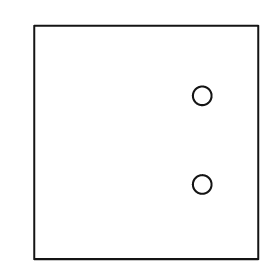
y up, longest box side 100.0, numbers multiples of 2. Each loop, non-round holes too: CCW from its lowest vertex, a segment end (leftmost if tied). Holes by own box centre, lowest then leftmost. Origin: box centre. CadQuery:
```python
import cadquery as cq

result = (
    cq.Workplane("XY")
    .moveTo(-48.0, -50.0)
    .lineTo(48.0, -50.0)
    .lineTo(48.0, 50.0)
    .lineTo(-48.0, 50.0)
    .close()
    .moveTo(24.0, -18.0)
    .circle(4.0)
    .moveTo(24.0, 20.0)
    .circle(4.0)
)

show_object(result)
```